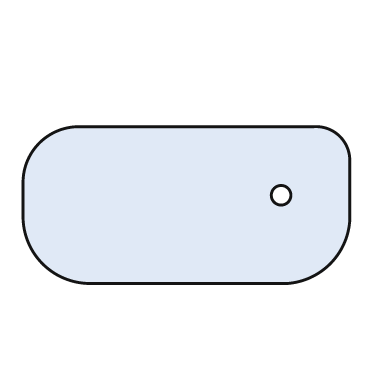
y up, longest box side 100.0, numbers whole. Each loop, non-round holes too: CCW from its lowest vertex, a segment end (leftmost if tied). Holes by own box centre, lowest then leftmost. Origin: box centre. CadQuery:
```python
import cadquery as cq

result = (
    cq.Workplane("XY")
    .moveTo(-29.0, -24.0)
    .lineTo(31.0, -24.0)
    .threePointArc((44.0, -18.0), (50.0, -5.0))
    .lineTo(50.0, 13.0)
    .threePointArc((47.0, 21.0), (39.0, 24.0))
    .lineTo(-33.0, 24.0)
    .threePointArc((-45.0, 19.0), (-50.0, 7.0))
    .lineTo(-50.0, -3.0)
    .threePointArc((-44.0, -18.0), (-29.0, -24.0))
    .close()
    .moveTo(29.0, 3.0)
    .circle(3.0)
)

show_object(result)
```